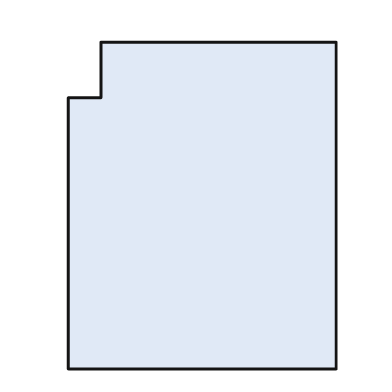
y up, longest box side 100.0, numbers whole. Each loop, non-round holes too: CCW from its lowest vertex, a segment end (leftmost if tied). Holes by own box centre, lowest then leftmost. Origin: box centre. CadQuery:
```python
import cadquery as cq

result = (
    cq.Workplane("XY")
    .moveTo(-41.0, -50.0)
    .lineTo(41.0, -50.0)
    .lineTo(41.0, 50.0)
    .lineTo(-31.0, 50.0)
    .lineTo(-31.0, 33.0)
    .lineTo(-41.0, 33.0)
    .close()
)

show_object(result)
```